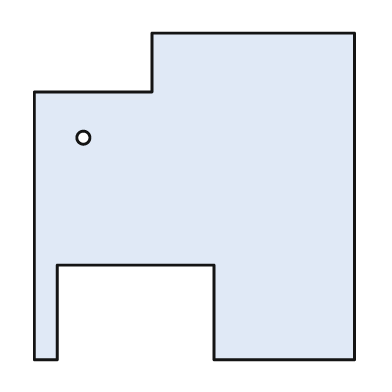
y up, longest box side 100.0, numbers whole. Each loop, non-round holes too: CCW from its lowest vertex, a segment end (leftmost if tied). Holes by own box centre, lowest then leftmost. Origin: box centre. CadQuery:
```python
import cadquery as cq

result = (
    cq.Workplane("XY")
    .moveTo(-49.0, -50.0)
    .lineTo(-42.0, -50.0)
    .lineTo(-42.0, -21.0)
    .lineTo(6.0, -21.0)
    .lineTo(6.0, -50.0)
    .lineTo(49.0, -50.0)
    .lineTo(49.0, 50.0)
    .lineTo(-13.0, 50.0)
    .lineTo(-13.0, 32.0)
    .lineTo(-49.0, 32.0)
    .close()
    .moveTo(-34.0, 18.0)
    .circle(2.0)
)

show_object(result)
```